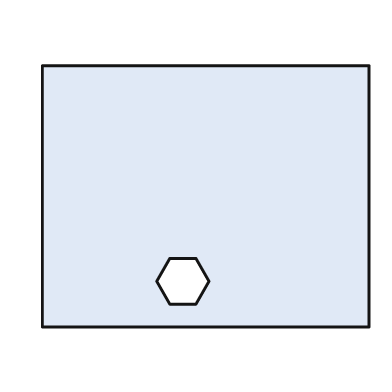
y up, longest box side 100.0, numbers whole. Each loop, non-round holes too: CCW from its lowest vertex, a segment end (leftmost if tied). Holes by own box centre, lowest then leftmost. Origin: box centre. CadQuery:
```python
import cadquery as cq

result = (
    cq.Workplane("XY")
    .moveTo(-50.0, -40.0)
    .lineTo(50.0, -40.0)
    .lineTo(50.0, 40.0)
    .lineTo(-50.0, 40.0)
    .close()
    .moveTo(-11.0, -33.0)
    .lineTo(-3.0, -33.0)
    .lineTo(1.0, -26.0)
    .lineTo(-3.0, -19.0)
    .lineTo(-11.0, -19.0)
    .lineTo(-15.0, -26.0)
    .close()
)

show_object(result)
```